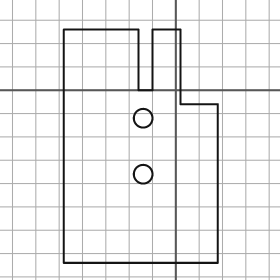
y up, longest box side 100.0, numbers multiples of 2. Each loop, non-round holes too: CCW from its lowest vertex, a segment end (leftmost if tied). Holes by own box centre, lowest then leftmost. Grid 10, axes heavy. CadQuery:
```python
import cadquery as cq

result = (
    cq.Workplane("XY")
    .moveTo(-48.0, -74.0)
    .lineTo(18.0, -74.0)
    .lineTo(18.0, -6.0)
    .lineTo(2.0, -6.0)
    .lineTo(2.0, 26.0)
    .lineTo(-10.0, 26.0)
    .lineTo(-10.0, 0.0)
    .lineTo(-16.0, 0.0)
    .lineTo(-16.0, 26.0)
    .lineTo(-48.0, 26.0)
    .close()
    .moveTo(-14.0, -36.0)
    .circle(4.0)
    .moveTo(-14.0, -12.0)
    .circle(4.0)
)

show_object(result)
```